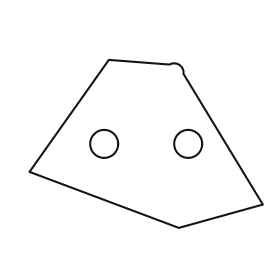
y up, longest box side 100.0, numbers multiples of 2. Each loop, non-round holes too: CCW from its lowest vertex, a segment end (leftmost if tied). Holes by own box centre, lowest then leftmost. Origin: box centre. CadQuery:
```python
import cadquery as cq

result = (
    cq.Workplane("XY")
    .moveTo(14.0, -36.0)
    .lineTo(50.0, -26.0)
    .lineTo(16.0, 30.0)
    .threePointArc((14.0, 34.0), (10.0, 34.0))
    .lineTo(-16.0, 36.0)
    .lineTo(-50.0, -12.0)
    .close()
    .moveTo(-18.0, 0.0)
    .circle(6.0)
    .moveTo(18.0, 0.0)
    .circle(6.0)
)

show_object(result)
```